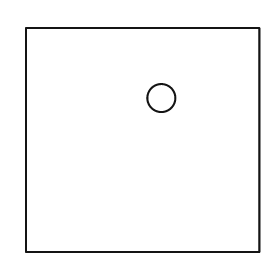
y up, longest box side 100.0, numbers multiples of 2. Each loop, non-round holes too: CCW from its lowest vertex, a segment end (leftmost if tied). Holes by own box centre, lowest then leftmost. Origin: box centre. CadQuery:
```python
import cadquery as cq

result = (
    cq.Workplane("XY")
    .moveTo(-50.0, -48.0)
    .lineTo(50.0, -48.0)
    .lineTo(50.0, 48.0)
    .lineTo(-50.0, 48.0)
    .close()
    .moveTo(8.0, 18.0)
    .circle(6.0)
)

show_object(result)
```